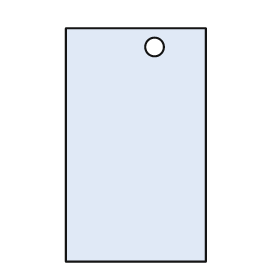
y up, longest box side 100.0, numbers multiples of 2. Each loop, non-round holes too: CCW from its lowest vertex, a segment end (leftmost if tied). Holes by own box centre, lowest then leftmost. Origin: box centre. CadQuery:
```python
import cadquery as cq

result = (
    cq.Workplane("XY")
    .moveTo(-30.0, -50.0)
    .lineTo(30.0, -50.0)
    .lineTo(30.0, 50.0)
    .lineTo(-30.0, 50.0)
    .close()
    .moveTo(8.0, 42.0)
    .circle(4.0)
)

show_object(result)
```